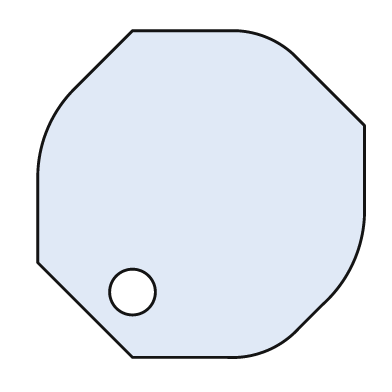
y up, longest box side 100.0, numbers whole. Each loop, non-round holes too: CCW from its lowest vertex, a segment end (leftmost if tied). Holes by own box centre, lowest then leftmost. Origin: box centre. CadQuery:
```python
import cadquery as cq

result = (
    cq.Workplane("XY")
    .moveTo(-21.0, -50.0)
    .lineTo(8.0, -50.0)
    .threePointArc((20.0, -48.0), (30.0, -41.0))
    .lineTo(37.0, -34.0)
    .threePointArc((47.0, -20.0), (50.0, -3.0))
    .lineTo(50.0, 21.0)
    .lineTo(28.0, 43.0)
    .threePointArc((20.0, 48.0), (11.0, 50.0))
    .lineTo(-21.0, 50.0)
    .lineTo(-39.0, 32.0)
    .threePointArc((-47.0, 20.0), (-50.0, 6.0))
    .lineTo(-50.0, -21.0)
    .close()
    .moveTo(-21.0, -30.0)
    .circle(7.0)
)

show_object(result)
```